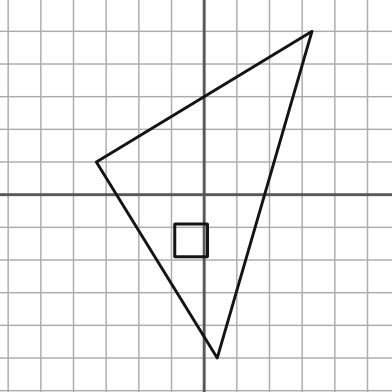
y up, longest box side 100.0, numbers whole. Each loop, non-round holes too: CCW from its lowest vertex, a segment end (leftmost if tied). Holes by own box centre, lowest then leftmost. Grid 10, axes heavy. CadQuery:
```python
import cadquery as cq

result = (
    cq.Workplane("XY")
    .moveTo(4.0, -50.0)
    .lineTo(33.0, 50.0)
    .lineTo(-33.0, 10.0)
    .close()
    .moveTo(-9.0, -19.0)
    .lineTo(1.0, -19.0)
    .lineTo(1.0, -9.0)
    .lineTo(-9.0, -9.0)
    .close()
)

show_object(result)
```